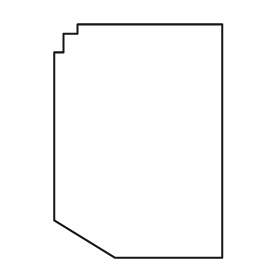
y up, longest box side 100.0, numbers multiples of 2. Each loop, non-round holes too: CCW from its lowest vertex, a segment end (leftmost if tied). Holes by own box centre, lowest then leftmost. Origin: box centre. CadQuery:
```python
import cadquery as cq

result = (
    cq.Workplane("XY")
    .moveTo(-10.0, -50.0)
    .lineTo(36.0, -50.0)
    .lineTo(36.0, 50.0)
    .lineTo(-26.0, 50.0)
    .lineTo(-26.0, 46.0)
    .lineTo(-32.0, 46.0)
    .lineTo(-32.0, 38.0)
    .lineTo(-36.0, 38.0)
    .lineTo(-36.0, -34.0)
    .close()
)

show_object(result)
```